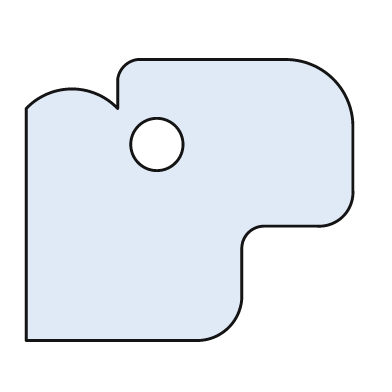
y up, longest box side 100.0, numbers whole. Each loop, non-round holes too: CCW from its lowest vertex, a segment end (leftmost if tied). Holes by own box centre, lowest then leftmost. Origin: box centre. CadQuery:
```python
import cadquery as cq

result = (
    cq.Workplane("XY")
    .moveTo(-50.0, -43.0)
    .lineTo(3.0, -43.0)
    .threePointArc((12.0, -39.0), (16.0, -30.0))
    .lineTo(16.0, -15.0)
    .threePointArc((18.0, -10.0), (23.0, -8.0))
    .lineTo(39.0, -8.0)
    .threePointArc((47.0, -5.0), (50.0, 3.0))
    .lineTo(50.0, 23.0)
    .threePointArc((44.0, 37.0), (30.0, 43.0))
    .lineTo(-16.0, 43.0)
    .threePointArc((-20.0, 41.0), (-22.0, 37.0))
    .lineTo(-22.0, 28.0)
    .threePointArc((-36.0, 34.0), (-50.0, 28.0))
    .close()
    .moveTo(-10.0, 17.0)
    .circle(8.0)
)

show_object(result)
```